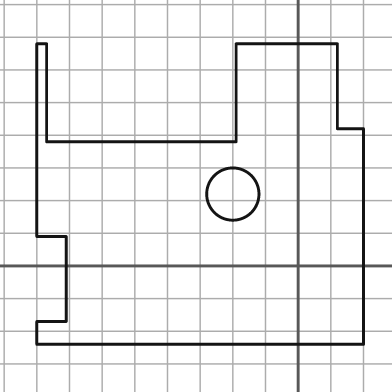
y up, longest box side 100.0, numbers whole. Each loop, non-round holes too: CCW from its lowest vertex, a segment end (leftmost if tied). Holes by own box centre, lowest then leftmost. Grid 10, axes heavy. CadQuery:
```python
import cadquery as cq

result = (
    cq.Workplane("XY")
    .moveTo(-80.0, -24.0)
    .lineTo(20.0, -24.0)
    .lineTo(20.0, 42.0)
    .lineTo(12.0, 42.0)
    .lineTo(12.0, 68.0)
    .lineTo(-19.0, 68.0)
    .lineTo(-19.0, 38.0)
    .lineTo(-77.0, 38.0)
    .lineTo(-77.0, 68.0)
    .lineTo(-80.0, 68.0)
    .lineTo(-80.0, 9.0)
    .lineTo(-71.0, 9.0)
    .lineTo(-71.0, -17.0)
    .lineTo(-80.0, -17.0)
    .close()
    .moveTo(-20.0, 22.0)
    .circle(8.0)
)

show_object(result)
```